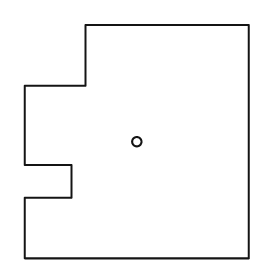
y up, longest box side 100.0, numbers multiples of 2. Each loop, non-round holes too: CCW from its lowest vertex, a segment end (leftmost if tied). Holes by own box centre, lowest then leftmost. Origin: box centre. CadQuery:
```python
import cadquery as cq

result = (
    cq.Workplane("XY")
    .moveTo(-48.0, -50.0)
    .lineTo(48.0, -50.0)
    .lineTo(48.0, 50.0)
    .lineTo(-22.0, 50.0)
    .lineTo(-22.0, 24.0)
    .lineTo(-48.0, 24.0)
    .lineTo(-48.0, -10.0)
    .lineTo(-28.0, -10.0)
    .lineTo(-28.0, -24.0)
    .lineTo(-48.0, -24.0)
    .close()
    .moveTo(0.0, 0.0)
    .circle(2.0)
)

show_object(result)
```